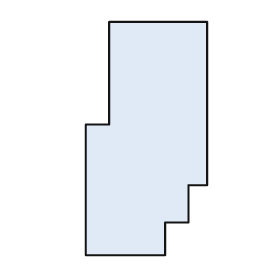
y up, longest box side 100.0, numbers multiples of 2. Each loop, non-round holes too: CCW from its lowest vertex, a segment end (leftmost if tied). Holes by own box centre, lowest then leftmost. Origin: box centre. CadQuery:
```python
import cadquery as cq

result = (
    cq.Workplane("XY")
    .moveTo(-26.0, -50.0)
    .lineTo(8.0, -50.0)
    .lineTo(8.0, -36.0)
    .lineTo(18.0, -36.0)
    .lineTo(18.0, -20.0)
    .lineTo(26.0, -20.0)
    .lineTo(26.0, 50.0)
    .lineTo(-16.0, 50.0)
    .lineTo(-16.0, 6.0)
    .lineTo(-26.0, 6.0)
    .close()
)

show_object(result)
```